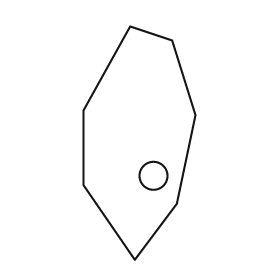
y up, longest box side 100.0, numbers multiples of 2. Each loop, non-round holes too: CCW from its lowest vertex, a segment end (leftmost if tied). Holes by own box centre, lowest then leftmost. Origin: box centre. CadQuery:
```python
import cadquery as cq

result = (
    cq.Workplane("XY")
    .moveTo(-2.0, -50.0)
    .lineTo(16.0, -26.0)
    .lineTo(24.0, 12.0)
    .lineTo(14.0, 44.0)
    .lineTo(-4.0, 50.0)
    .lineTo(-24.0, 14.0)
    .lineTo(-24.0, -18.0)
    .close()
    .moveTo(6.0, -14.0)
    .circle(6.0)
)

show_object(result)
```